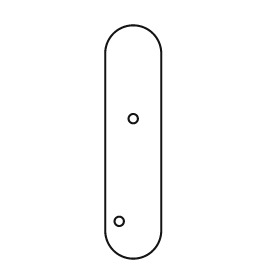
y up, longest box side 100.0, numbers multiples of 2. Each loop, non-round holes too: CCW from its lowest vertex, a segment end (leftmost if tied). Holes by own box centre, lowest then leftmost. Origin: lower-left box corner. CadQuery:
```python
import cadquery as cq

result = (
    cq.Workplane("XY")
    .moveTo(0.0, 12.0)
    .threePointArc((12.0, 0.0), (24.0, 12.0))
    .lineTo(24.0, 88.0)
    .threePointArc((12.0, 100.0), (0.0, 88.0))
    .close()
    .moveTo(6.0, 16.0)
    .circle(2.0)
    .moveTo(12.0, 60.0)
    .circle(2.0)
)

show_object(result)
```